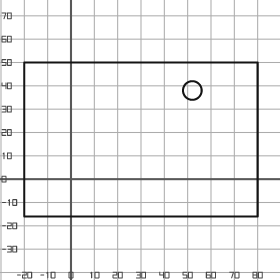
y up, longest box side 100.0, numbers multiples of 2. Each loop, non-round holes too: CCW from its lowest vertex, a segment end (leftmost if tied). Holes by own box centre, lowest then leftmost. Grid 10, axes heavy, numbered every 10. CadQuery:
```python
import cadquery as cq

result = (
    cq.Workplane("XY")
    .moveTo(-20.0, -16.0)
    .lineTo(80.0, -16.0)
    .lineTo(80.0, 50.0)
    .lineTo(-20.0, 50.0)
    .close()
    .moveTo(52.0, 38.0)
    .circle(4.0)
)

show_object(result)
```